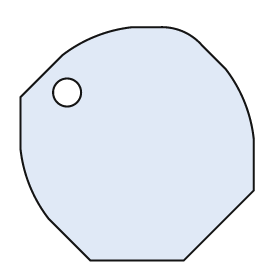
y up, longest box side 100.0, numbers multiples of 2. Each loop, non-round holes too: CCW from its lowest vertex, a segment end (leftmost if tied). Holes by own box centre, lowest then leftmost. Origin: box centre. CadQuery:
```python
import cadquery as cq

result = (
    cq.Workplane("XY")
    .moveTo(-20.0, -50.0)
    .lineTo(20.0, -50.0)
    .lineTo(50.0, -20.0)
    .lineTo(50.0, 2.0)
    .threePointArc((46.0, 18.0), (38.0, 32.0))
    .lineTo(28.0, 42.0)
    .threePointArc((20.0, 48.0), (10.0, 50.0))
    .lineTo(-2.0, 50.0)
    .threePointArc((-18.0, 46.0), (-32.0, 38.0))
    .lineTo(-50.0, 20.0)
    .lineTo(-50.0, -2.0)
    .threePointArc((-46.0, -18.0), (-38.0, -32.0))
    .close()
    .moveTo(-30.0, 22.0)
    .circle(6.0)
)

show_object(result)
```